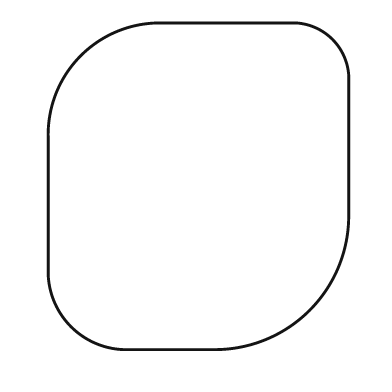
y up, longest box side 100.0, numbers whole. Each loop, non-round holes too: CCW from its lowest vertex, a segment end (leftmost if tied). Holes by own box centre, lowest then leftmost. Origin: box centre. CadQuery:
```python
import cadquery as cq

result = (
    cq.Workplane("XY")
    .moveTo(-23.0, -50.0)
    .lineTo(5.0, -50.0)
    .threePointArc((34.0, -38.0), (46.0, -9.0))
    .lineTo(46.0, 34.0)
    .threePointArc((41.0, 45.0), (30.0, 50.0))
    .lineTo(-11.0, 50.0)
    .threePointArc((-36.0, 40.0), (-46.0, 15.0))
    .lineTo(-46.0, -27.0)
    .threePointArc((-39.0, -43.0), (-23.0, -50.0))
    .close()
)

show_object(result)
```